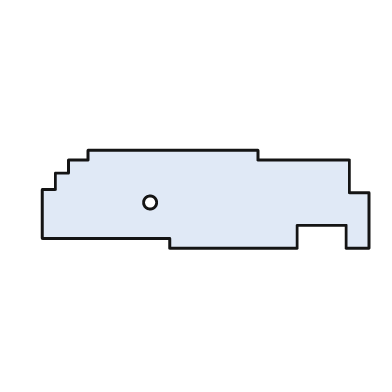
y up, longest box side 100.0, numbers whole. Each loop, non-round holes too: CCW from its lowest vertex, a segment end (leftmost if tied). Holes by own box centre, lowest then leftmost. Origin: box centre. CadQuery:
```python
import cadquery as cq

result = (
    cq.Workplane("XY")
    .moveTo(-11.0, -15.0)
    .lineTo(28.0, -15.0)
    .lineTo(28.0, -8.0)
    .lineTo(43.0, -8.0)
    .lineTo(43.0, -15.0)
    .lineTo(50.0, -15.0)
    .lineTo(50.0, 2.0)
    .lineTo(44.0, 2.0)
    .lineTo(44.0, 12.0)
    .lineTo(16.0, 12.0)
    .lineTo(16.0, 15.0)
    .lineTo(-36.0, 15.0)
    .lineTo(-36.0, 12.0)
    .lineTo(-42.0, 12.0)
    .lineTo(-42.0, 8.0)
    .lineTo(-46.0, 8.0)
    .lineTo(-46.0, 3.0)
    .lineTo(-50.0, 3.0)
    .lineTo(-50.0, -12.0)
    .lineTo(-11.0, -12.0)
    .close()
    .moveTo(-17.0, -1.0)
    .circle(2.0)
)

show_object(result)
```